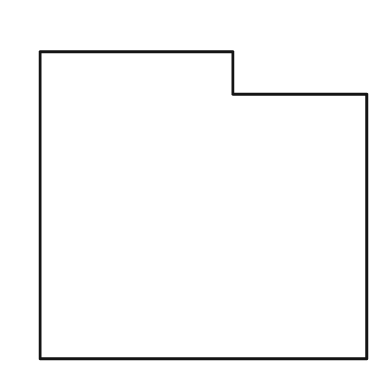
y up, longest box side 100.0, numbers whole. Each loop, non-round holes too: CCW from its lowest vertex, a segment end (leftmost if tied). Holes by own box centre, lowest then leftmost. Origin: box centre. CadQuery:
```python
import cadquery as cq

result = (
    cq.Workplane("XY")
    .moveTo(-50.0, -47.0)
    .lineTo(50.0, -47.0)
    .lineTo(50.0, 34.0)
    .lineTo(9.0, 34.0)
    .lineTo(9.0, 47.0)
    .lineTo(-50.0, 47.0)
    .close()
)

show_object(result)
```